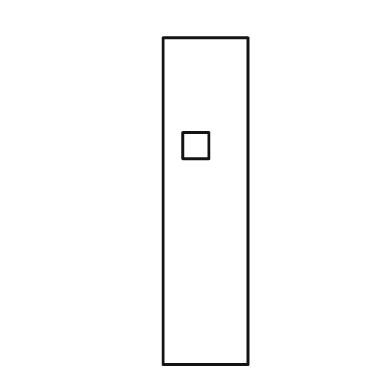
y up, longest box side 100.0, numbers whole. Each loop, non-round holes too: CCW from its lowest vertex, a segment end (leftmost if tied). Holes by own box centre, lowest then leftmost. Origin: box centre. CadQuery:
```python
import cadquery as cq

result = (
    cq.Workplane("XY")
    .moveTo(-13.0, -50.0)
    .lineTo(13.0, -50.0)
    .lineTo(13.0, 50.0)
    .lineTo(-13.0, 50.0)
    .close()
    .moveTo(-7.0, 13.0)
    .lineTo(1.0, 13.0)
    .lineTo(1.0, 21.0)
    .lineTo(-7.0, 21.0)
    .close()
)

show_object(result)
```